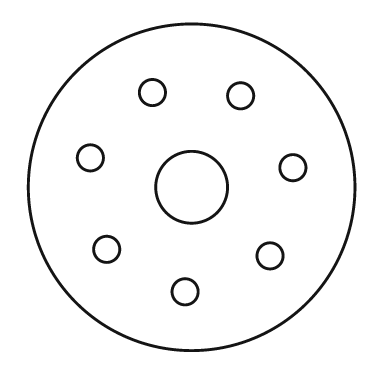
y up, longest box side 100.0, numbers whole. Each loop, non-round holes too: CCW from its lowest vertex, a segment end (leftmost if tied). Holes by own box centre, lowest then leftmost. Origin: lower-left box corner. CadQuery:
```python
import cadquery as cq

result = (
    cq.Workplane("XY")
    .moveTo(50.0, 50.0)
    .circle(50.0)
    .moveTo(48.0, 18.0)
    .circle(4.0)
    .moveTo(74.0, 29.0)
    .circle(4.0)
    .moveTo(24.0, 31.0)
    .circle(4.0)
    .moveTo(50.0, 50.0)
    .circle(11.0)
    .moveTo(81.0, 56.0)
    .circle(4.0)
    .moveTo(19.0, 59.0)
    .circle(4.0)
    .moveTo(65.0, 78.0)
    .circle(4.0)
    .moveTo(38.0, 79.0)
    .circle(4.0)
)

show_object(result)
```